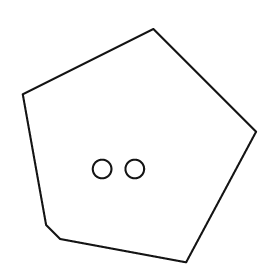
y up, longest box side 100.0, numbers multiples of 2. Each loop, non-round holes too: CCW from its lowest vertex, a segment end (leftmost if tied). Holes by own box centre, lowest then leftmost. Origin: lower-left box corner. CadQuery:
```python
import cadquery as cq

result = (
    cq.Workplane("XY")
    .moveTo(70.0, 0.0)
    .lineTo(100.0, 56.0)
    .lineTo(56.0, 100.0)
    .lineTo(0.0, 72.0)
    .lineTo(10.0, 16.0)
    .lineTo(16.0, 10.0)
    .close()
    .moveTo(34.0, 40.0)
    .circle(4.0)
    .moveTo(48.0, 40.0)
    .circle(4.0)
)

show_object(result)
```